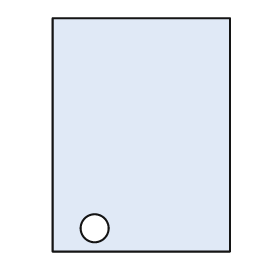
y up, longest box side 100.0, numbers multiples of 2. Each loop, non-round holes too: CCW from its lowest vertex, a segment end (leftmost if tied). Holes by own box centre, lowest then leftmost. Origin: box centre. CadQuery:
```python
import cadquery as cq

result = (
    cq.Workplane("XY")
    .moveTo(-38.0, -50.0)
    .lineTo(38.0, -50.0)
    .lineTo(38.0, 50.0)
    .lineTo(-38.0, 50.0)
    .close()
    .moveTo(-20.0, -40.0)
    .circle(6.0)
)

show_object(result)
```